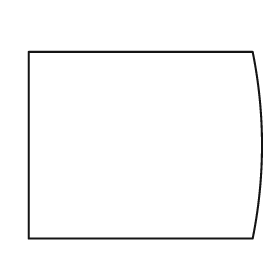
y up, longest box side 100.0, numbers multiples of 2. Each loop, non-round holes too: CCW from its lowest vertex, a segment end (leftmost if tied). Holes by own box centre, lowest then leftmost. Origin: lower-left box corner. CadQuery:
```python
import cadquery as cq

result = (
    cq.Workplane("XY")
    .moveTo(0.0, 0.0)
    .lineTo(96.0, 0.0)
    .threePointArc((100.0, 40.0), (96.0, 80.0))
    .lineTo(0.0, 80.0)
    .close()
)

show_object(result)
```